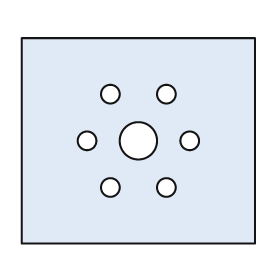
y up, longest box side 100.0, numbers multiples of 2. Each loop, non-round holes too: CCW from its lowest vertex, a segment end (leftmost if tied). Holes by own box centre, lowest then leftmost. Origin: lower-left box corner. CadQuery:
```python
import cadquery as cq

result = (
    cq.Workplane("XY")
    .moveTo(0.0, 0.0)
    .lineTo(100.0, 0.0)
    .lineTo(100.0, 88.0)
    .lineTo(0.0, 88.0)
    .close()
    .moveTo(38.0, 24.0)
    .circle(4.0)
    .moveTo(62.0, 24.0)
    .circle(4.0)
    .moveTo(28.0, 44.0)
    .circle(4.0)
    .moveTo(50.0, 44.0)
    .circle(8.0)
    .moveTo(72.0, 44.0)
    .circle(4.0)
    .moveTo(38.0, 64.0)
    .circle(4.0)
    .moveTo(62.0, 64.0)
    .circle(4.0)
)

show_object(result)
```